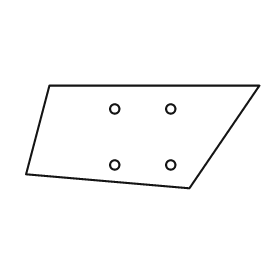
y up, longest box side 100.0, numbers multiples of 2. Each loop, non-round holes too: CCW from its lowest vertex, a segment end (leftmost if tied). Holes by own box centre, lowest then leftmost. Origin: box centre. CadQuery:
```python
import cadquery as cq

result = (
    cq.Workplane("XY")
    .moveTo(20.0, -22.0)
    .lineTo(50.0, 22.0)
    .lineTo(-40.0, 22.0)
    .lineTo(-50.0, -16.0)
    .close()
    .moveTo(-12.0, -12.0)
    .circle(2.0)
    .moveTo(12.0, -12.0)
    .circle(2.0)
    .moveTo(-12.0, 12.0)
    .circle(2.0)
    .moveTo(12.0, 12.0)
    .circle(2.0)
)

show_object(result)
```